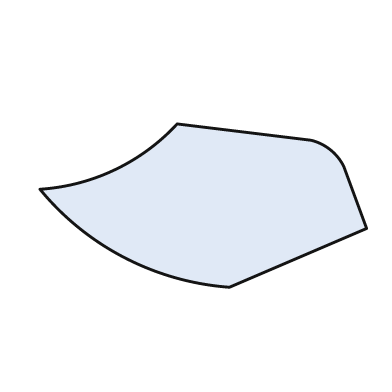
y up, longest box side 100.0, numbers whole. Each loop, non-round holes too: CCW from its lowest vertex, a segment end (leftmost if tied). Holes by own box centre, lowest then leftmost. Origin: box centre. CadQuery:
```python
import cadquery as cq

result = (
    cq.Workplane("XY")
    .moveTo(8.0, -25.0)
    .lineTo(50.0, -7.0)
    .lineTo(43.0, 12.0)
    .threePointArc((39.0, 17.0), (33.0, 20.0))
    .lineTo(-8.0, 25.0)
    .threePointArc((-27.0, 11.0), (-50.0, 5.0))
    .threePointArc((-24.0, -16.0), (8.0, -25.0))
    .close()
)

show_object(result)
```